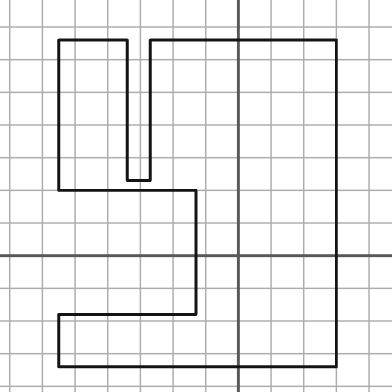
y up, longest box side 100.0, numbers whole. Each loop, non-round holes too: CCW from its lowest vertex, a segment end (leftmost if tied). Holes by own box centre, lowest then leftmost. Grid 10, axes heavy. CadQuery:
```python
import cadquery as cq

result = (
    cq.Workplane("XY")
    .moveTo(-55.0, -34.0)
    .lineTo(30.0, -34.0)
    .lineTo(30.0, 66.0)
    .lineTo(-27.0, 66.0)
    .lineTo(-27.0, 23.0)
    .lineTo(-34.0, 23.0)
    .lineTo(-34.0, 66.0)
    .lineTo(-55.0, 66.0)
    .lineTo(-55.0, 20.0)
    .lineTo(-13.0, 20.0)
    .lineTo(-13.0, -18.0)
    .lineTo(-55.0, -18.0)
    .close()
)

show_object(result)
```